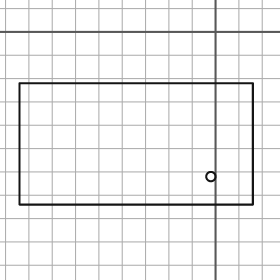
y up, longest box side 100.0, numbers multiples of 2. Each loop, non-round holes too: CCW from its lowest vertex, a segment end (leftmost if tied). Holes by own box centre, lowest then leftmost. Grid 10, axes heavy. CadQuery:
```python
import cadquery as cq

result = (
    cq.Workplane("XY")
    .moveTo(-84.0, -74.0)
    .lineTo(16.0, -74.0)
    .lineTo(16.0, -22.0)
    .lineTo(-84.0, -22.0)
    .close()
    .moveTo(-2.0, -62.0)
    .circle(2.0)
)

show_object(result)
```